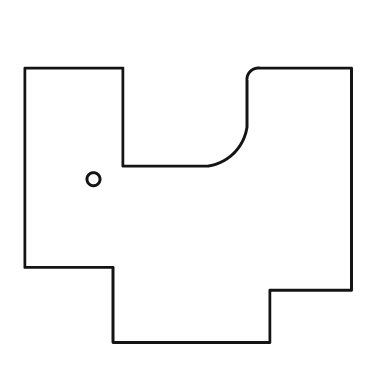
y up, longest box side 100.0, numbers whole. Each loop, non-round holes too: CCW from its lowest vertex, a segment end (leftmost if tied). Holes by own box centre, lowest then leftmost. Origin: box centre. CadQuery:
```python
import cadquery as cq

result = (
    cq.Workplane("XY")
    .moveTo(-23.0, -42.0)
    .lineTo(25.0, -42.0)
    .lineTo(25.0, -26.0)
    .lineTo(50.0, -26.0)
    .lineTo(50.0, 42.0)
    .lineTo(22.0, 42.0)
    .threePointArc((19.0, 41.0), (18.0, 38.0))
    .lineTo(18.0, 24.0)
    .threePointArc((14.0, 16.0), (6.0, 12.0))
    .lineTo(-20.0, 12.0)
    .lineTo(-20.0, 42.0)
    .lineTo(-50.0, 42.0)
    .lineTo(-50.0, -19.0)
    .lineTo(-23.0, -19.0)
    .close()
    .moveTo(-29.0, 8.0)
    .circle(2.0)
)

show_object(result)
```